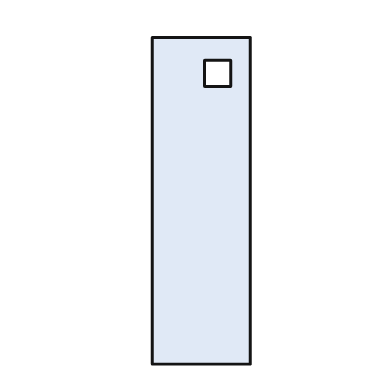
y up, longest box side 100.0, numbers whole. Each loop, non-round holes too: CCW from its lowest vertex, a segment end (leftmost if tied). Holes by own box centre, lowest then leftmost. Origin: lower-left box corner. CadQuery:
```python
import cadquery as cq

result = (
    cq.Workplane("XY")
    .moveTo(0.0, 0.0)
    .lineTo(30.0, 0.0)
    .lineTo(30.0, 100.0)
    .lineTo(0.0, 100.0)
    .close()
    .moveTo(16.0, 85.0)
    .lineTo(24.0, 85.0)
    .lineTo(24.0, 93.0)
    .lineTo(16.0, 93.0)
    .close()
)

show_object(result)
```